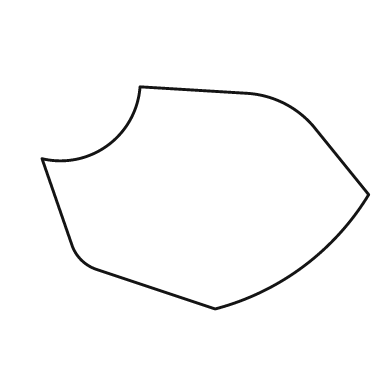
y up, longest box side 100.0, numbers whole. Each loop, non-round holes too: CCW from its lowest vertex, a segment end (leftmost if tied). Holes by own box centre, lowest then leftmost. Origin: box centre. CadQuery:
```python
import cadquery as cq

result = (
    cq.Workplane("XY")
    .moveTo(3.0, -34.0)
    .threePointArc((30.0, -21.0), (50.0, 1.0))
    .lineTo(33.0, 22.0)
    .threePointArc((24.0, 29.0), (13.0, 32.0))
    .lineTo(-20.0, 34.0)
    .threePointArc((-30.0, 16.0), (-50.0, 12.0))
    .lineTo(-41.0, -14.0)
    .threePointArc((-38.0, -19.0), (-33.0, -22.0))
    .close()
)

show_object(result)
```